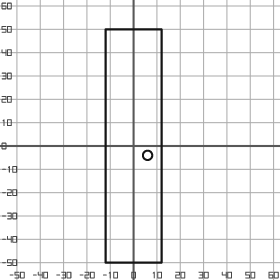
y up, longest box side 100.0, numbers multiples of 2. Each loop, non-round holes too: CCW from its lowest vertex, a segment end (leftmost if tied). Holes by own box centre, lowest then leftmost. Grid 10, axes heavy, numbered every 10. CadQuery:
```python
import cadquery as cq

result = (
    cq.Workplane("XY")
    .moveTo(-12.0, -50.0)
    .lineTo(12.0, -50.0)
    .lineTo(12.0, 50.0)
    .lineTo(-12.0, 50.0)
    .close()
    .moveTo(6.0, -4.0)
    .circle(2.0)
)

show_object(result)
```